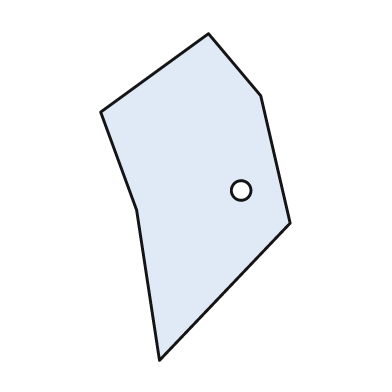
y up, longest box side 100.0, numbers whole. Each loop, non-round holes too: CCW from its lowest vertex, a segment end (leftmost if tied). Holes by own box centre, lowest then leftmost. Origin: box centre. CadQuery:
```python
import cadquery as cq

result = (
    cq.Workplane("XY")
    .moveTo(-11.0, -50.0)
    .lineTo(29.0, -8.0)
    .lineTo(20.0, 31.0)
    .lineTo(4.0, 50.0)
    .lineTo(-29.0, 26.0)
    .lineTo(-18.0, -4.0)
    .close()
    .moveTo(14.0, 2.0)
    .circle(3.0)
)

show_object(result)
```